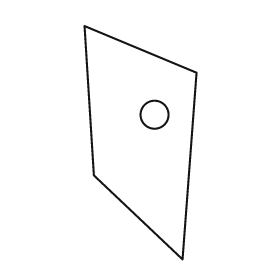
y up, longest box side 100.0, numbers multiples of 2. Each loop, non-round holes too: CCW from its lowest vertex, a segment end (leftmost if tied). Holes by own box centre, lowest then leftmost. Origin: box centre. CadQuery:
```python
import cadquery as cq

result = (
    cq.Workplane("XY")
    .moveTo(18.0, -50.0)
    .lineTo(24.0, 30.0)
    .lineTo(-24.0, 50.0)
    .lineTo(-20.0, -14.0)
    .close()
    .moveTo(6.0, 12.0)
    .circle(6.0)
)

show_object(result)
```